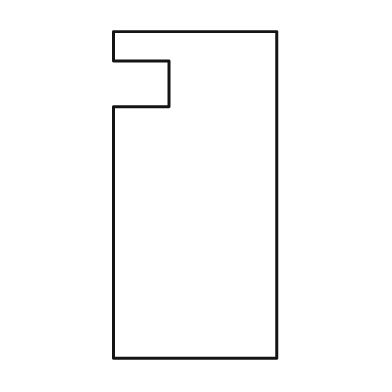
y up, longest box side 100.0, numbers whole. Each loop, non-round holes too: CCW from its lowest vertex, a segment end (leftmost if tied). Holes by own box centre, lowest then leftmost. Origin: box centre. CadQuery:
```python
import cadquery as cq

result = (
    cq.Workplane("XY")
    .moveTo(-25.0, -50.0)
    .lineTo(25.0, -50.0)
    .lineTo(25.0, 50.0)
    .lineTo(-25.0, 50.0)
    .lineTo(-25.0, 41.0)
    .lineTo(-8.0, 41.0)
    .lineTo(-8.0, 27.0)
    .lineTo(-25.0, 27.0)
    .close()
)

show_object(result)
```